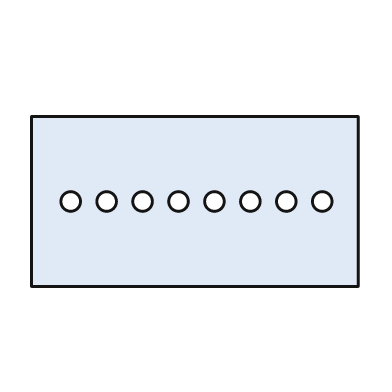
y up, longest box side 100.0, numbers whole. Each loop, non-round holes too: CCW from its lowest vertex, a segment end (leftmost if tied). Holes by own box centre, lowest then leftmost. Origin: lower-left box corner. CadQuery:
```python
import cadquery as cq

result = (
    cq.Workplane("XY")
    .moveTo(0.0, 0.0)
    .lineTo(100.0, 0.0)
    .lineTo(100.0, 52.0)
    .lineTo(0.0, 52.0)
    .close()
    .moveTo(12.0, 26.0)
    .circle(3.0)
    .moveTo(23.0, 26.0)
    .circle(3.0)
    .moveTo(34.0, 26.0)
    .circle(3.0)
    .moveTo(45.0, 26.0)
    .circle(3.0)
    .moveTo(56.0, 26.0)
    .circle(3.0)
    .moveTo(67.0, 26.0)
    .circle(3.0)
    .moveTo(78.0, 26.0)
    .circle(3.0)
    .moveTo(89.0, 26.0)
    .circle(3.0)
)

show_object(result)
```